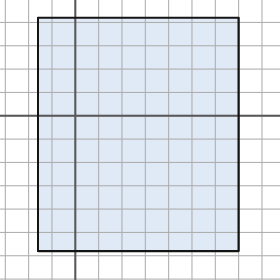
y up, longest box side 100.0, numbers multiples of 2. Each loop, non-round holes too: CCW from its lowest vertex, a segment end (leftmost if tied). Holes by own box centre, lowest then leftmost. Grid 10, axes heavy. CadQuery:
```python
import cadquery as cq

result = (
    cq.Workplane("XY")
    .moveTo(-16.0, -58.0)
    .lineTo(70.0, -58.0)
    .lineTo(70.0, 42.0)
    .lineTo(-16.0, 42.0)
    .close()
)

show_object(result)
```